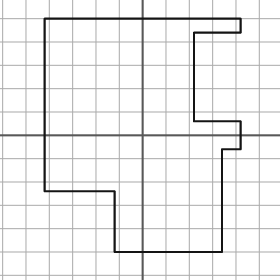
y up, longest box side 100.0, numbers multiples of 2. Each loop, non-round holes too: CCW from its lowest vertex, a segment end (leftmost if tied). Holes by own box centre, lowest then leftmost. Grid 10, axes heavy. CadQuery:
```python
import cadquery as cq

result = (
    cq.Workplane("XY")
    .moveTo(-12.0, -50.0)
    .lineTo(34.0, -50.0)
    .lineTo(34.0, -6.0)
    .lineTo(42.0, -6.0)
    .lineTo(42.0, 6.0)
    .lineTo(22.0, 6.0)
    .lineTo(22.0, 44.0)
    .lineTo(42.0, 44.0)
    .lineTo(42.0, 50.0)
    .lineTo(-42.0, 50.0)
    .lineTo(-42.0, -24.0)
    .lineTo(-12.0, -24.0)
    .close()
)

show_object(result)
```